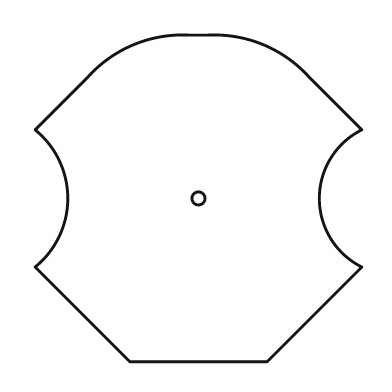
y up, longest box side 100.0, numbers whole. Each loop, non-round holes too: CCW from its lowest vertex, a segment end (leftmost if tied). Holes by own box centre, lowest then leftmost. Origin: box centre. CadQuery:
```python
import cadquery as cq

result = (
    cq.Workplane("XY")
    .moveTo(-21.0, -50.0)
    .lineTo(21.0, -50.0)
    .lineTo(50.0, -21.0)
    .threePointArc((37.0, 0.0), (50.0, 21.0))
    .lineTo(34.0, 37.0)
    .threePointArc((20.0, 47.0), (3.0, 50.0))
    .lineTo(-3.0, 50.0)
    .threePointArc((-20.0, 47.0), (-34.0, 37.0))
    .lineTo(-50.0, 21.0)
    .threePointArc((-40.0, 0.0), (-50.0, -21.0))
    .close()
    .moveTo(0.0, 0.0)
    .circle(2.0)
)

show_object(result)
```